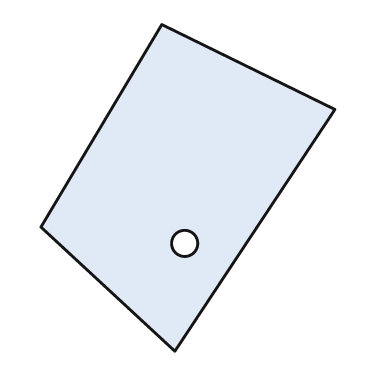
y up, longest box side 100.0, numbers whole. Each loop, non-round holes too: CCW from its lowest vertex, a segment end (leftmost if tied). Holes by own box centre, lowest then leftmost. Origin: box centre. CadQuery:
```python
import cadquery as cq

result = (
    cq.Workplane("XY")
    .moveTo(-4.0, -50.0)
    .lineTo(45.0, 24.0)
    .lineTo(-8.0, 50.0)
    .lineTo(-45.0, -12.0)
    .close()
    .moveTo(-1.0, -17.0)
    .circle(4.0)
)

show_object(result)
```